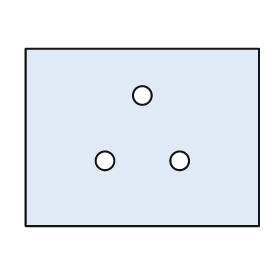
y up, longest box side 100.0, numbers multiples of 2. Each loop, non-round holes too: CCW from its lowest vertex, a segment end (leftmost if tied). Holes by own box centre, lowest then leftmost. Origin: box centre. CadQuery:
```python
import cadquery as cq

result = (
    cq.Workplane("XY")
    .moveTo(-50.0, -38.0)
    .lineTo(50.0, -38.0)
    .lineTo(50.0, 38.0)
    .lineTo(-50.0, 38.0)
    .close()
    .moveTo(-16.0, -10.0)
    .circle(4.0)
    .moveTo(16.0, -10.0)
    .circle(4.0)
    .moveTo(0.0, 18.0)
    .circle(4.0)
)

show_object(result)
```